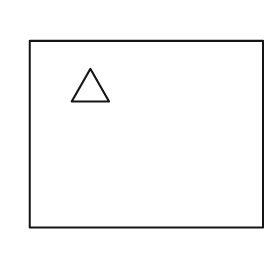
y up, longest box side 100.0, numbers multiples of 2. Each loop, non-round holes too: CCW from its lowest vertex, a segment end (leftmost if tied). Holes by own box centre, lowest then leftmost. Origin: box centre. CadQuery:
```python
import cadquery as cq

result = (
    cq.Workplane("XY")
    .moveTo(-50.0, -40.0)
    .lineTo(50.0, -40.0)
    .lineTo(50.0, 40.0)
    .lineTo(-50.0, 40.0)
    .close()
    .moveTo(-32.0, 14.0)
    .lineTo(-16.0, 14.0)
    .lineTo(-24.0, 28.0)
    .close()
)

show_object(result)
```